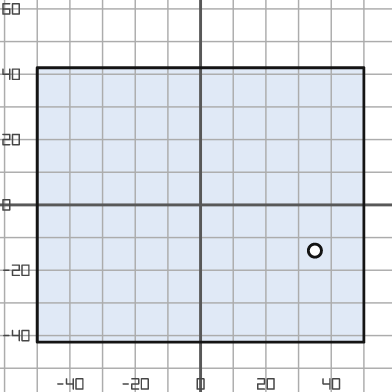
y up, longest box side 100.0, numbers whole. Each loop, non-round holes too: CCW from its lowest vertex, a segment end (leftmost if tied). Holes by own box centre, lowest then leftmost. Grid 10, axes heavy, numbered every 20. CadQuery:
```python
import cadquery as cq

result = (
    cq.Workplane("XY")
    .moveTo(-50.0, -42.0)
    .lineTo(50.0, -42.0)
    .lineTo(50.0, 42.0)
    .lineTo(-50.0, 42.0)
    .close()
    .moveTo(35.0, -14.0)
    .circle(2.0)
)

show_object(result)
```